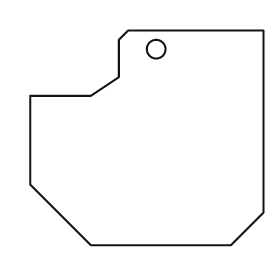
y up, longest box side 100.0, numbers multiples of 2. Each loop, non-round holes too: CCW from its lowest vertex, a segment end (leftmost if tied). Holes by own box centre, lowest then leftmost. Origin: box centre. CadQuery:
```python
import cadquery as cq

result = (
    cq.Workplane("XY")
    .moveTo(-24.0, -46.0)
    .lineTo(36.0, -46.0)
    .lineTo(50.0, -32.0)
    .lineTo(50.0, 46.0)
    .lineTo(-8.0, 46.0)
    .lineTo(-12.0, 42.0)
    .lineTo(-12.0, 26.0)
    .lineTo(-24.0, 18.0)
    .lineTo(-50.0, 18.0)
    .lineTo(-50.0, -20.0)
    .close()
    .moveTo(4.0, 38.0)
    .circle(4.0)
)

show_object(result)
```